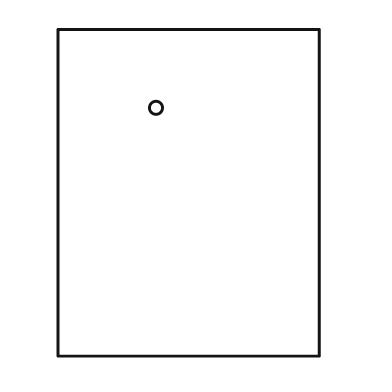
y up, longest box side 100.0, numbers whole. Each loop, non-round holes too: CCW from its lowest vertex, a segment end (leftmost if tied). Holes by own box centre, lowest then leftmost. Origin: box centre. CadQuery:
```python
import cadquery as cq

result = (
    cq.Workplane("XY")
    .moveTo(-40.0, -50.0)
    .lineTo(40.0, -50.0)
    .lineTo(40.0, 50.0)
    .lineTo(-40.0, 50.0)
    .close()
    .moveTo(-10.0, 26.0)
    .circle(2.0)
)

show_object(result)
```